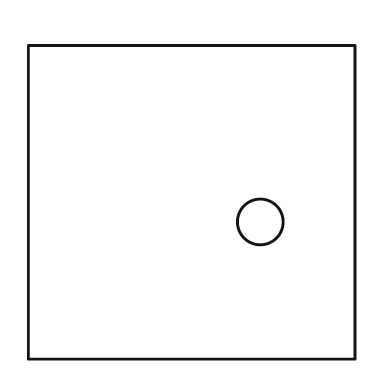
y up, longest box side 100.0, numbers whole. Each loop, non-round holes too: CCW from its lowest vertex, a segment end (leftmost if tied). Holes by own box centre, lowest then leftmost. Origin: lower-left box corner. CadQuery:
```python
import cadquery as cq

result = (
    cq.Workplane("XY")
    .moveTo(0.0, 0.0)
    .lineTo(100.0, 0.0)
    .lineTo(100.0, 96.0)
    .lineTo(0.0, 96.0)
    .close()
    .moveTo(71.0, 42.0)
    .circle(7.0)
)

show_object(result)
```